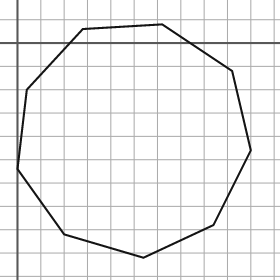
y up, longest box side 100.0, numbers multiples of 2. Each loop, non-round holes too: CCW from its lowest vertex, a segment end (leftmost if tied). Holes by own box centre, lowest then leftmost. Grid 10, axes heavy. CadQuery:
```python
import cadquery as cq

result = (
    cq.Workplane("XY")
    .moveTo(54.0, -92.0)
    .lineTo(84.0, -78.0)
    .lineTo(100.0, -46.0)
    .lineTo(92.0, -12.0)
    .lineTo(62.0, 8.0)
    .lineTo(28.0, 6.0)
    .lineTo(4.0, -20.0)
    .lineTo(0.0, -54.0)
    .lineTo(20.0, -82.0)
    .close()
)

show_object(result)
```